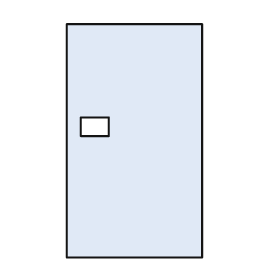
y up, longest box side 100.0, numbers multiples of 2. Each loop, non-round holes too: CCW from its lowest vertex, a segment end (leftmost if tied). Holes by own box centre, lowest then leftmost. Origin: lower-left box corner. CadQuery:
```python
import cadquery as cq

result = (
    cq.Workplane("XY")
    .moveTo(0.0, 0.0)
    .lineTo(58.0, 0.0)
    .lineTo(58.0, 100.0)
    .lineTo(0.0, 100.0)
    .close()
    .moveTo(6.0, 52.0)
    .lineTo(18.0, 52.0)
    .lineTo(18.0, 60.0)
    .lineTo(6.0, 60.0)
    .close()
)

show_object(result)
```